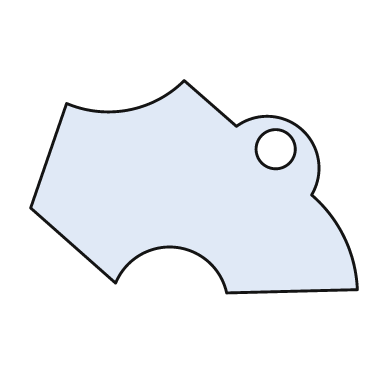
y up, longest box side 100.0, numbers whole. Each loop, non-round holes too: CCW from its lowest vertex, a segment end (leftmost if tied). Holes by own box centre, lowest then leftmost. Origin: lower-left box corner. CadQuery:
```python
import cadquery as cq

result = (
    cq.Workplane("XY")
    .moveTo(60.0, 0.0)
    .lineTo(100.0, 1.0)
    .threePointArc((96.0, 17.0), (86.0, 30.0))
    .threePointArc((83.0, 50.0), (63.0, 51.0))
    .lineTo(47.0, 65.0)
    .threePointArc((30.0, 56.0), (11.0, 58.0))
    .lineTo(0.0, 26.0)
    .lineTo(26.0, 3.0)
    .threePointArc((44.0, 14.0), (60.0, 0.0))
    .close()
    .moveTo(75.0, 44.0)
    .circle(6.0)
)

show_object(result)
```